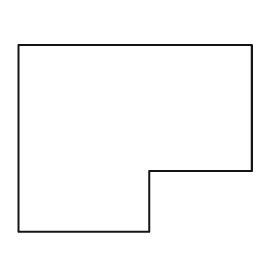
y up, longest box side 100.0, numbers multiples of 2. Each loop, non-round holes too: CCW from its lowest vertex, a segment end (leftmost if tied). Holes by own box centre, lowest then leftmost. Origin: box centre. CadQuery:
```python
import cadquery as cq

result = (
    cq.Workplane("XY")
    .moveTo(-50.0, -40.0)
    .lineTo(6.0, -40.0)
    .lineTo(6.0, -14.0)
    .lineTo(50.0, -14.0)
    .lineTo(50.0, 40.0)
    .lineTo(-50.0, 40.0)
    .close()
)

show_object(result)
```